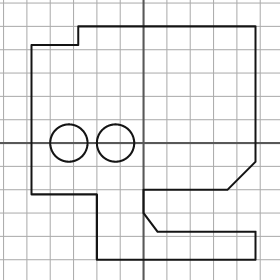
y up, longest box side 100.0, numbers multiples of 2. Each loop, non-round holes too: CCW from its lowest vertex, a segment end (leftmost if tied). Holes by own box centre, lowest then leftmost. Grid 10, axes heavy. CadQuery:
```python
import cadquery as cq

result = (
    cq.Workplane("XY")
    .moveTo(-20.0, -50.0)
    .lineTo(48.0, -50.0)
    .lineTo(48.0, -38.0)
    .lineTo(6.0, -38.0)
    .lineTo(0.0, -30.0)
    .lineTo(0.0, -20.0)
    .lineTo(36.0, -20.0)
    .lineTo(48.0, -8.0)
    .lineTo(48.0, 50.0)
    .lineTo(-28.0, 50.0)
    .lineTo(-28.0, 42.0)
    .lineTo(-48.0, 42.0)
    .lineTo(-48.0, -22.0)
    .lineTo(-20.0, -22.0)
    .close()
    .moveTo(-32.0, 0.0)
    .circle(8.0)
    .moveTo(-12.0, 0.0)
    .circle(8.0)
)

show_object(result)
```